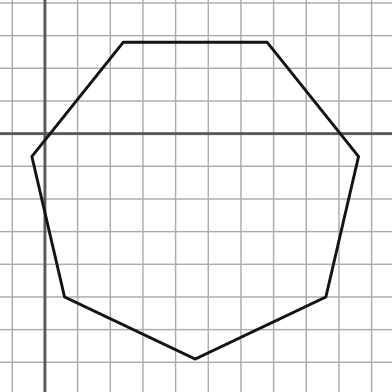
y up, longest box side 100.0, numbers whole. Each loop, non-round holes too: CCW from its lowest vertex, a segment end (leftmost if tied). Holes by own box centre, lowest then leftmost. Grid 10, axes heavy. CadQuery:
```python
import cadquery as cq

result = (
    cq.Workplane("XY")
    .moveTo(46.0, -69.0)
    .lineTo(86.0, -50.0)
    .lineTo(96.0, -7.0)
    .lineTo(68.0, 28.0)
    .lineTo(24.0, 28.0)
    .lineTo(-4.0, -7.0)
    .lineTo(6.0, -50.0)
    .close()
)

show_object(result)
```